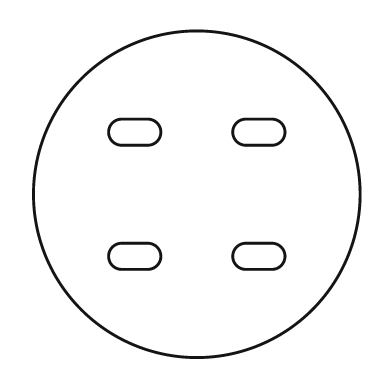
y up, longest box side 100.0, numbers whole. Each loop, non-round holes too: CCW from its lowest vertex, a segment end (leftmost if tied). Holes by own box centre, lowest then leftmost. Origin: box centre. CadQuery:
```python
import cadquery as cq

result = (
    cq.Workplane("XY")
    .moveTo(0.0, 0.0)
    .circle(50.0)
    .moveTo(-23.0, -23.0)
    .lineTo(-15.0, -23.0)
    .threePointArc((-11.0, -19.0), (-15.0, -15.0))
    .lineTo(-23.0, -15.0)
    .threePointArc((-27.0, -19.0), (-23.0, -23.0))
    .close()
    .moveTo(15.0, -23.0)
    .lineTo(23.0, -23.0)
    .threePointArc((27.0, -19.0), (23.0, -15.0))
    .lineTo(15.0, -15.0)
    .threePointArc((11.0, -19.0), (15.0, -23.0))
    .close()
    .moveTo(-23.0, 15.0)
    .lineTo(-15.0, 15.0)
    .threePointArc((-11.0, 19.0), (-15.0, 23.0))
    .lineTo(-23.0, 23.0)
    .threePointArc((-27.0, 19.0), (-23.0, 15.0))
    .close()
    .moveTo(15.0, 15.0)
    .lineTo(23.0, 15.0)
    .threePointArc((27.0, 19.0), (23.0, 23.0))
    .lineTo(15.0, 23.0)
    .threePointArc((11.0, 19.0), (15.0, 15.0))
    .close()
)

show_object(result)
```